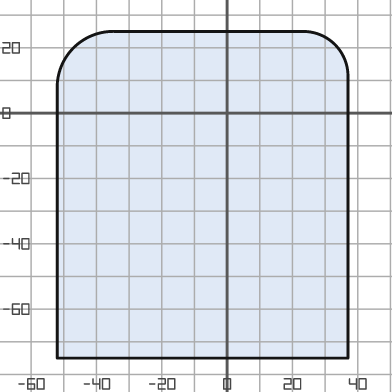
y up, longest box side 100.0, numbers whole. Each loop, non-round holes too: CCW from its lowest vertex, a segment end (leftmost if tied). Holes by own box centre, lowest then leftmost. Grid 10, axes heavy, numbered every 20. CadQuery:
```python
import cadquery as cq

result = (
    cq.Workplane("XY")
    .moveTo(-52.0, -75.0)
    .lineTo(37.0, -75.0)
    .lineTo(37.0, 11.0)
    .threePointArc((33.0, 21.0), (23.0, 25.0))
    .lineTo(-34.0, 25.0)
    .threePointArc((-47.0, 20.0), (-52.0, 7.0))
    .close()
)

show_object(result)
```